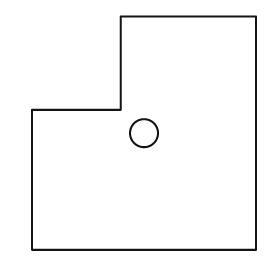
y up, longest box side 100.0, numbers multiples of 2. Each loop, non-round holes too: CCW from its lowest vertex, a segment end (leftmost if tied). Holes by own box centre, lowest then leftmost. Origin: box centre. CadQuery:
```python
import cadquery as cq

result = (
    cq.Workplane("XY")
    .moveTo(-48.0, -50.0)
    .lineTo(48.0, -50.0)
    .lineTo(48.0, 50.0)
    .lineTo(-10.0, 50.0)
    .lineTo(-10.0, 10.0)
    .lineTo(-48.0, 10.0)
    .close()
    .moveTo(0.0, 0.0)
    .circle(6.0)
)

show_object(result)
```